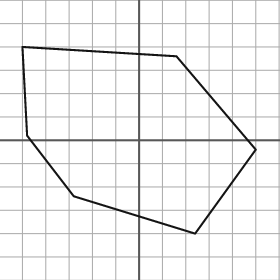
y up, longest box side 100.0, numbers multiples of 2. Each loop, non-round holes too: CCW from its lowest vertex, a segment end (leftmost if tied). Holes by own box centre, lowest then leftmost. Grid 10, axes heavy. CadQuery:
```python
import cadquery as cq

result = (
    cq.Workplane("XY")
    .moveTo(24.0, -40.0)
    .lineTo(50.0, -4.0)
    .lineTo(16.0, 36.0)
    .lineTo(-50.0, 40.0)
    .lineTo(-48.0, 2.0)
    .lineTo(-28.0, -24.0)
    .close()
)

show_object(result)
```